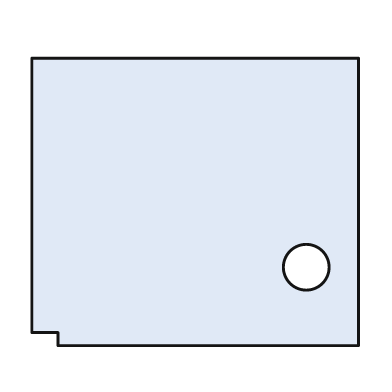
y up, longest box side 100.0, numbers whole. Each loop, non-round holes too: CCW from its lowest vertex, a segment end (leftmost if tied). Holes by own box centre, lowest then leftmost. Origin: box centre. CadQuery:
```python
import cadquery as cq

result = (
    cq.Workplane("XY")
    .moveTo(-42.0, -44.0)
    .lineTo(50.0, -44.0)
    .lineTo(50.0, 44.0)
    .lineTo(-50.0, 44.0)
    .lineTo(-50.0, -40.0)
    .lineTo(-42.0, -40.0)
    .close()
    .moveTo(34.0, -20.0)
    .circle(7.0)
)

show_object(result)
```